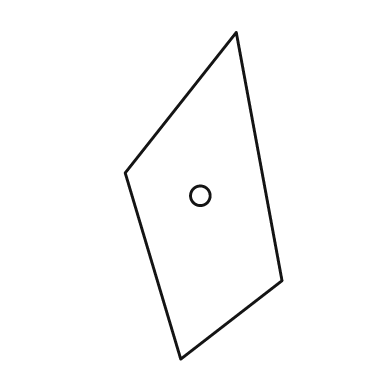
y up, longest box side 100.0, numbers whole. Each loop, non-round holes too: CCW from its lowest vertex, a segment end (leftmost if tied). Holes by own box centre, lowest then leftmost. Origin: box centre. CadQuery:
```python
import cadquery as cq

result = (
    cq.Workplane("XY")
    .moveTo(-7.0, -50.0)
    .lineTo(24.0, -26.0)
    .lineTo(10.0, 50.0)
    .lineTo(-24.0, 7.0)
    .close()
    .moveTo(-1.0, 0.0)
    .circle(3.0)
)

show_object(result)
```